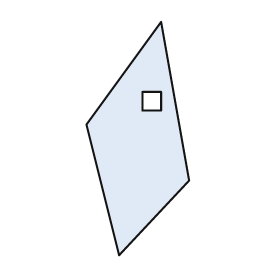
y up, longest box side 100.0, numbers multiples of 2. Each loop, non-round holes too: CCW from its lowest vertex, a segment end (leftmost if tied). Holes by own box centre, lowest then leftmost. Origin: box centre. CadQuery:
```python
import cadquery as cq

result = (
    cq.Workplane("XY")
    .moveTo(-8.0, -50.0)
    .lineTo(22.0, -18.0)
    .lineTo(10.0, 50.0)
    .lineTo(-22.0, 6.0)
    .close()
    .moveTo(2.0, 12.0)
    .lineTo(10.0, 12.0)
    .lineTo(10.0, 20.0)
    .lineTo(2.0, 20.0)
    .close()
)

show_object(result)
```